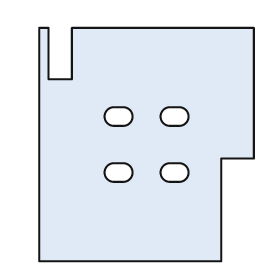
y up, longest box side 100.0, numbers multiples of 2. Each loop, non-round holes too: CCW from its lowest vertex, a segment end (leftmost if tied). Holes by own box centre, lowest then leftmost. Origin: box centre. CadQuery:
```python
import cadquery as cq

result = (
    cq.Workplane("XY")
    .moveTo(-46.0, -50.0)
    .lineTo(32.0, -50.0)
    .lineTo(32.0, -6.0)
    .lineTo(46.0, -6.0)
    .lineTo(46.0, 50.0)
    .lineTo(-32.0, 50.0)
    .lineTo(-32.0, 28.0)
    .lineTo(-42.0, 28.0)
    .lineTo(-42.0, 50.0)
    .lineTo(-46.0, 50.0)
    .close()
    .moveTo(-14.0, -16.0)
    .lineTo(-10.0, -16.0)
    .threePointArc((-6.0, -12.0), (-10.0, -8.0))
    .lineTo(-14.0, -8.0)
    .threePointArc((-18.0, -12.0), (-14.0, -16.0))
    .close()
    .moveTo(10.0, -16.0)
    .lineTo(14.0, -16.0)
    .threePointArc((18.0, -12.0), (14.0, -8.0))
    .lineTo(10.0, -8.0)
    .threePointArc((6.0, -12.0), (10.0, -16.0))
    .close()
    .moveTo(-14.0, 8.0)
    .lineTo(-10.0, 8.0)
    .threePointArc((-6.0, 12.0), (-10.0, 16.0))
    .lineTo(-14.0, 16.0)
    .threePointArc((-18.0, 12.0), (-14.0, 8.0))
    .close()
    .moveTo(10.0, 8.0)
    .lineTo(14.0, 8.0)
    .threePointArc((18.0, 12.0), (14.0, 16.0))
    .lineTo(10.0, 16.0)
    .threePointArc((6.0, 12.0), (10.0, 8.0))
    .close()
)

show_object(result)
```